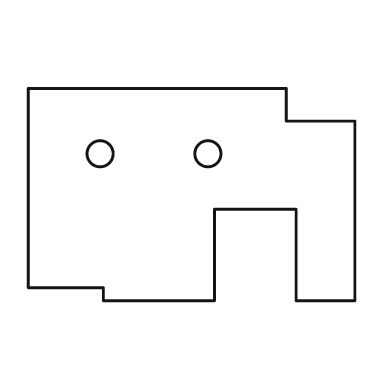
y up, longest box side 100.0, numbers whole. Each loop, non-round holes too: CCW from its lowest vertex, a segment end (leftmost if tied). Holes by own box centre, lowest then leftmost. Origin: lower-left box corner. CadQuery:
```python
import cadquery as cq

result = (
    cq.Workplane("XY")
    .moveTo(23.0, 0.0)
    .lineTo(57.0, 0.0)
    .lineTo(57.0, 28.0)
    .lineTo(82.0, 28.0)
    .lineTo(82.0, 0.0)
    .lineTo(100.0, 0.0)
    .lineTo(100.0, 55.0)
    .lineTo(79.0, 55.0)
    .lineTo(79.0, 65.0)
    .lineTo(0.0, 65.0)
    .lineTo(0.0, 4.0)
    .lineTo(23.0, 4.0)
    .close()
    .moveTo(22.0, 45.0)
    .circle(4.0)
    .moveTo(55.0, 45.0)
    .circle(4.0)
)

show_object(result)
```